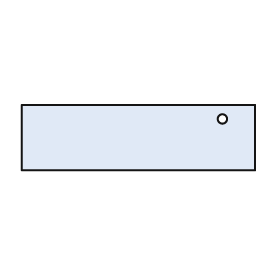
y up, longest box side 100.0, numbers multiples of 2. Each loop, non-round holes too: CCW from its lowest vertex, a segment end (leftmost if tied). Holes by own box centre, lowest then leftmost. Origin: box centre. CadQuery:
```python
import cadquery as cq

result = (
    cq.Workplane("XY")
    .moveTo(-50.0, -14.0)
    .lineTo(50.0, -14.0)
    .lineTo(50.0, 14.0)
    .lineTo(-50.0, 14.0)
    .close()
    .moveTo(36.0, 8.0)
    .circle(2.0)
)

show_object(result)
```